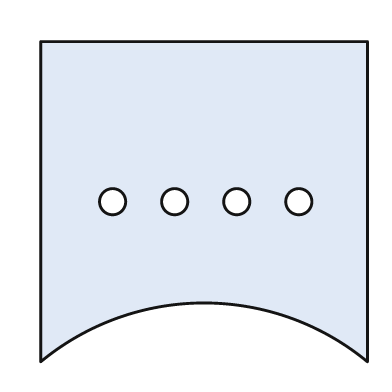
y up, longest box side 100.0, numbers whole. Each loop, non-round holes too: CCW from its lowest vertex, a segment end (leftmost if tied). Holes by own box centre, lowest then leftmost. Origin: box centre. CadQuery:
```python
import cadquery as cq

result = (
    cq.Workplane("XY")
    .moveTo(-50.0, -49.0)
    .threePointArc((0.0, -31.0), (50.0, -49.0))
    .lineTo(50.0, 49.0)
    .lineTo(-50.0, 49.0)
    .close()
    .moveTo(-28.0, 0.0)
    .circle(4.0)
    .moveTo(-9.0, 0.0)
    .circle(4.0)
    .moveTo(10.0, 0.0)
    .circle(4.0)
    .moveTo(29.0, 0.0)
    .circle(4.0)
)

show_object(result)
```